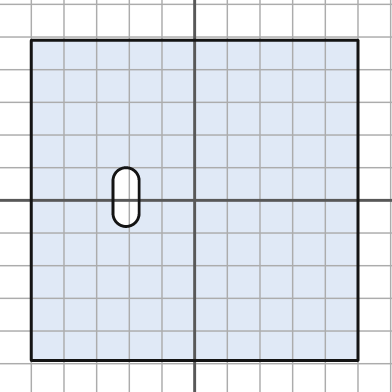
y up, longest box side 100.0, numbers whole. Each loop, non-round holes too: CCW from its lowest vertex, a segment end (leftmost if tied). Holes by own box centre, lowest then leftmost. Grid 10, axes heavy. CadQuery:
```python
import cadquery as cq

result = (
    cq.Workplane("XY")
    .moveTo(-50.0, -49.0)
    .lineTo(50.0, -49.0)
    .lineTo(50.0, 49.0)
    .lineTo(-50.0, 49.0)
    .close()
    .moveTo(-25.0, -4.0)
    .threePointArc((-21.0, -8.0), (-17.0, -4.0))
    .lineTo(-17.0, 6.0)
    .threePointArc((-21.0, 10.0), (-25.0, 6.0))
    .close()
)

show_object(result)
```